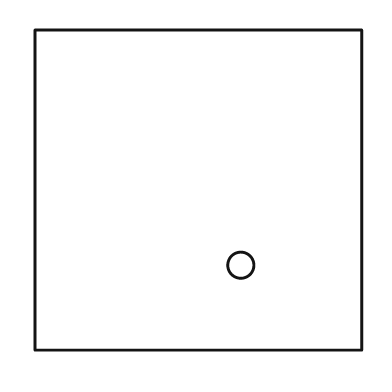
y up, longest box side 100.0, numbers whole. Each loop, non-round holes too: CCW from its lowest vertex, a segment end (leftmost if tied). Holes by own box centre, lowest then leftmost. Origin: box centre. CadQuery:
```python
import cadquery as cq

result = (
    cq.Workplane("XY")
    .moveTo(-50.0, -49.0)
    .lineTo(50.0, -49.0)
    .lineTo(50.0, 49.0)
    .lineTo(-50.0, 49.0)
    .close()
    .moveTo(13.0, -23.0)
    .circle(4.0)
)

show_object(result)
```